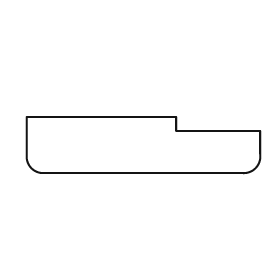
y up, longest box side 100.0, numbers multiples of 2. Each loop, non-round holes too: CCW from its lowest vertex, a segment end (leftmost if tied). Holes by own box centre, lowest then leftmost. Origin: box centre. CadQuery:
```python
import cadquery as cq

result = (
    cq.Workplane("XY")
    .moveTo(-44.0, -12.0)
    .lineTo(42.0, -12.0)
    .threePointArc((48.0, -10.0), (50.0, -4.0))
    .lineTo(50.0, 6.0)
    .lineTo(14.0, 6.0)
    .lineTo(14.0, 12.0)
    .lineTo(-50.0, 12.0)
    .lineTo(-50.0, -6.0)
    .threePointArc((-48.0, -10.0), (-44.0, -12.0))
    .close()
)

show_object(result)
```